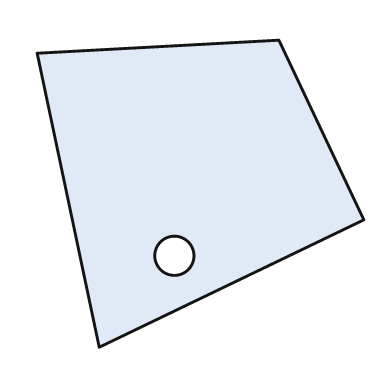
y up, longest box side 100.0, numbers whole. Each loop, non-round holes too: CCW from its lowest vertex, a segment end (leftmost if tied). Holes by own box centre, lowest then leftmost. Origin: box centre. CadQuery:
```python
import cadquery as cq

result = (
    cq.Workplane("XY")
    .moveTo(-31.0, -47.0)
    .lineTo(50.0, -8.0)
    .lineTo(24.0, 47.0)
    .lineTo(-50.0, 43.0)
    .close()
    .moveTo(-8.0, -19.0)
    .circle(6.0)
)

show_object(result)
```